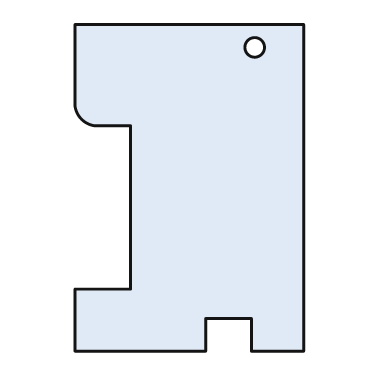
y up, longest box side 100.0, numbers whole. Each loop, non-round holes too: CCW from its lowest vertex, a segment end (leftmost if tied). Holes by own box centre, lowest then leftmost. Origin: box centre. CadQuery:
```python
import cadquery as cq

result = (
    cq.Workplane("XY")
    .moveTo(-35.0, -50.0)
    .lineTo(5.0, -50.0)
    .lineTo(5.0, -40.0)
    .lineTo(19.0, -40.0)
    .lineTo(19.0, -50.0)
    .lineTo(35.0, -50.0)
    .lineTo(35.0, 50.0)
    .lineTo(-35.0, 50.0)
    .lineTo(-35.0, 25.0)
    .threePointArc((-33.0, 21.0), (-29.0, 19.0))
    .lineTo(-18.0, 19.0)
    .lineTo(-18.0, -31.0)
    .lineTo(-35.0, -31.0)
    .close()
    .moveTo(20.0, 43.0)
    .circle(3.0)
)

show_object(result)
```